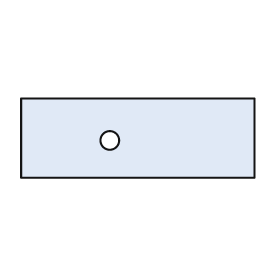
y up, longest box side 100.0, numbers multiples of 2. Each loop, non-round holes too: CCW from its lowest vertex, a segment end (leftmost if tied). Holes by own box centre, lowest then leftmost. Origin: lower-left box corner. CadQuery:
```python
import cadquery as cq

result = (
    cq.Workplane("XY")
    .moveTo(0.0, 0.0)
    .lineTo(100.0, 0.0)
    .lineTo(100.0, 34.0)
    .lineTo(0.0, 34.0)
    .close()
    .moveTo(38.0, 16.0)
    .circle(4.0)
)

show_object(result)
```